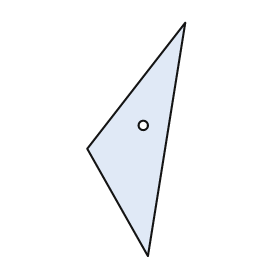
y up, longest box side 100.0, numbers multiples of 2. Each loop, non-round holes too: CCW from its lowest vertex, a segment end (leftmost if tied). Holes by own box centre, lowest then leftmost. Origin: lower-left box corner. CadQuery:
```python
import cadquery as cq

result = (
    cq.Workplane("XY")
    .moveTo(26.0, 0.0)
    .lineTo(42.0, 100.0)
    .lineTo(0.0, 46.0)
    .close()
    .moveTo(24.0, 56.0)
    .circle(2.0)
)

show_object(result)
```